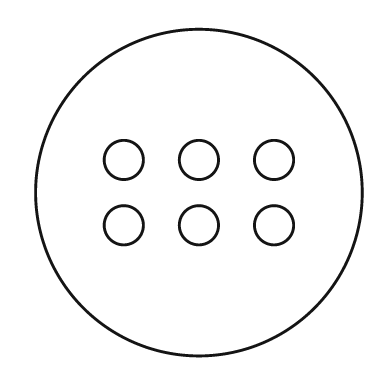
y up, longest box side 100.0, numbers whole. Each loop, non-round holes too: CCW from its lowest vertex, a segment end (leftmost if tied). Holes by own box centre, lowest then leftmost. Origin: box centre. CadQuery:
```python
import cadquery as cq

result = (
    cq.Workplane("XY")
    .moveTo(0.0, 0.0)
    .circle(50.0)
    .moveTo(-23.0, -10.0)
    .circle(6.0)
    .moveTo(0.0, -10.0)
    .circle(6.0)
    .moveTo(23.0, -10.0)
    .circle(6.0)
    .moveTo(-23.0, 10.0)
    .circle(6.0)
    .moveTo(0.0, 10.0)
    .circle(6.0)
    .moveTo(23.0, 10.0)
    .circle(6.0)
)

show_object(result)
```